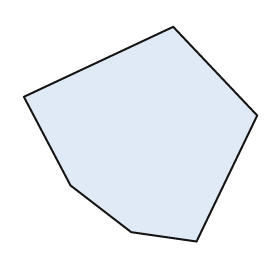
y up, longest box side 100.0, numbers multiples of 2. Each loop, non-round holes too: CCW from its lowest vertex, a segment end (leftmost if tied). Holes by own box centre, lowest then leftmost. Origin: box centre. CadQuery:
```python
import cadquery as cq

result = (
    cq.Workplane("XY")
    .moveTo(24.0, -46.0)
    .lineTo(50.0, 8.0)
    .lineTo(14.0, 46.0)
    .lineTo(-50.0, 16.0)
    .lineTo(-30.0, -22.0)
    .lineTo(-4.0, -42.0)
    .close()
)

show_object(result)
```